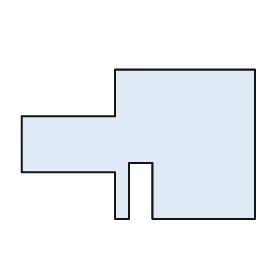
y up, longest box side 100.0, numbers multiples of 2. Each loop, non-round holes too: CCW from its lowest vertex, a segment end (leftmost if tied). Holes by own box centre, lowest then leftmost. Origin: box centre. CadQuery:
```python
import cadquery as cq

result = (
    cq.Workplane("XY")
    .moveTo(-10.0, -32.0)
    .lineTo(-4.0, -32.0)
    .lineTo(-4.0, -8.0)
    .lineTo(6.0, -8.0)
    .lineTo(6.0, -32.0)
    .lineTo(50.0, -32.0)
    .lineTo(50.0, 32.0)
    .lineTo(-10.0, 32.0)
    .lineTo(-10.0, 12.0)
    .lineTo(-50.0, 12.0)
    .lineTo(-50.0, -12.0)
    .lineTo(-10.0, -12.0)
    .close()
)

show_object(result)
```